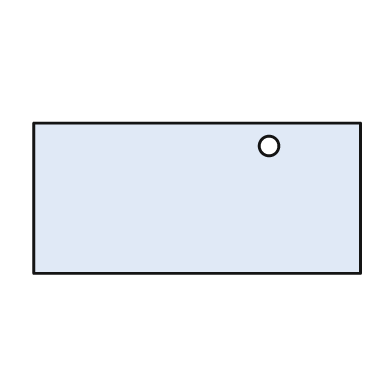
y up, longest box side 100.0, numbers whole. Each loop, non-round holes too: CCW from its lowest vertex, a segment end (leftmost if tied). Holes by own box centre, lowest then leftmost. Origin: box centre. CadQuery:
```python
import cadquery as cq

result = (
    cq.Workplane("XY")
    .moveTo(-50.0, -23.0)
    .lineTo(50.0, -23.0)
    .lineTo(50.0, 23.0)
    .lineTo(-50.0, 23.0)
    .close()
    .moveTo(22.0, 16.0)
    .circle(3.0)
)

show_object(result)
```